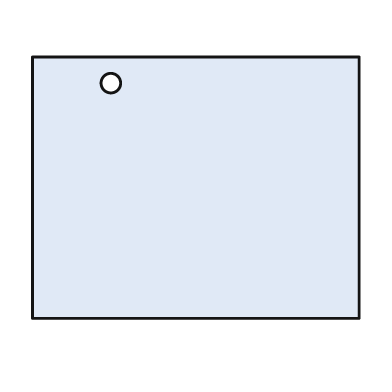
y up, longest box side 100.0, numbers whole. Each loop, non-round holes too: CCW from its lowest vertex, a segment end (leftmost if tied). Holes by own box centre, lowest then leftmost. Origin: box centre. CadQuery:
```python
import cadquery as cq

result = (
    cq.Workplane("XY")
    .moveTo(-50.0, -40.0)
    .lineTo(50.0, -40.0)
    .lineTo(50.0, 40.0)
    .lineTo(-50.0, 40.0)
    .close()
    .moveTo(-26.0, 32.0)
    .circle(3.0)
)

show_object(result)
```